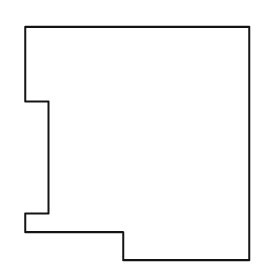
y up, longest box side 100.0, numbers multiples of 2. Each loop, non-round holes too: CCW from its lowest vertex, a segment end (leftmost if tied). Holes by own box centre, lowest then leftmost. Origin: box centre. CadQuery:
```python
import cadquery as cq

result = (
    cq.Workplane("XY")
    .moveTo(-6.0, -50.0)
    .lineTo(48.0, -50.0)
    .lineTo(48.0, 50.0)
    .lineTo(-48.0, 50.0)
    .lineTo(-48.0, 18.0)
    .lineTo(-38.0, 18.0)
    .lineTo(-38.0, -30.0)
    .lineTo(-48.0, -30.0)
    .lineTo(-48.0, -38.0)
    .lineTo(-6.0, -38.0)
    .close()
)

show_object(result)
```